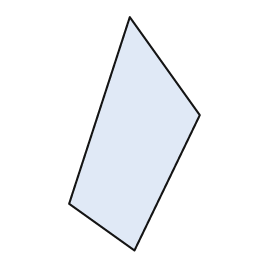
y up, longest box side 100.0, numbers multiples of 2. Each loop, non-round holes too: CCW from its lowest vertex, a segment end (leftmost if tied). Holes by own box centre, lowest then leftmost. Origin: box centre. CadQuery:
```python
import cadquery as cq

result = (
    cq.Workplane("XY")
    .moveTo(0.0, -50.0)
    .lineTo(28.0, 8.0)
    .lineTo(-2.0, 50.0)
    .lineTo(-28.0, -30.0)
    .close()
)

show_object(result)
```